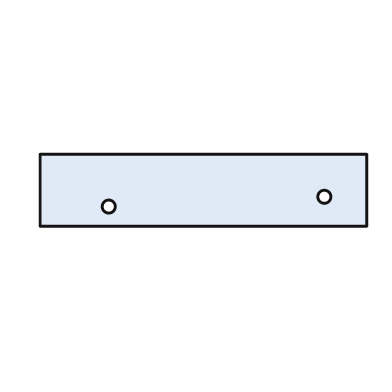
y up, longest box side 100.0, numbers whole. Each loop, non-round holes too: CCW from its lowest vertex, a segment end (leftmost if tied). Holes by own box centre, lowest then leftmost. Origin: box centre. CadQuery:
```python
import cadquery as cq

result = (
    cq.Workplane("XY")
    .moveTo(-50.0, -11.0)
    .lineTo(50.0, -11.0)
    .lineTo(50.0, 11.0)
    .lineTo(-50.0, 11.0)
    .close()
    .moveTo(-29.0, -5.0)
    .circle(2.0)
    .moveTo(37.0, -2.0)
    .circle(2.0)
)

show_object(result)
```